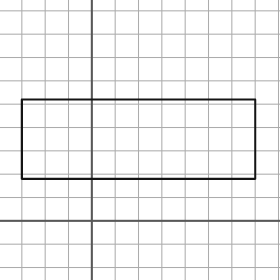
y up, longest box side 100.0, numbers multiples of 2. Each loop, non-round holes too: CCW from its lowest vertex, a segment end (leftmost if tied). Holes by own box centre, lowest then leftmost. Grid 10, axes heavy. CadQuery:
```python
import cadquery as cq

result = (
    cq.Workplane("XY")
    .moveTo(-30.0, 18.0)
    .lineTo(70.0, 18.0)
    .lineTo(70.0, 52.0)
    .lineTo(-30.0, 52.0)
    .close()
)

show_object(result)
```